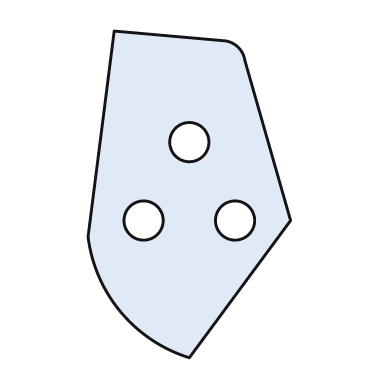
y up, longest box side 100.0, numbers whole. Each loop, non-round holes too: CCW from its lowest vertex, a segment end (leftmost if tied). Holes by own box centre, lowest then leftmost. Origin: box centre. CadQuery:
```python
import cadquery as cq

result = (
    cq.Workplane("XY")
    .moveTo(0.0, -50.0)
    .lineTo(31.0, -8.0)
    .lineTo(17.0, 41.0)
    .threePointArc((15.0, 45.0), (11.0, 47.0))
    .lineTo(-23.0, 50.0)
    .lineTo(-31.0, -13.0)
    .threePointArc((-21.0, -36.0), (0.0, -50.0))
    .close()
    .moveTo(-14.0, -8.0)
    .circle(6.0)
    .moveTo(14.0, -8.0)
    .circle(6.0)
    .moveTo(0.0, 16.0)
    .circle(6.0)
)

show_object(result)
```